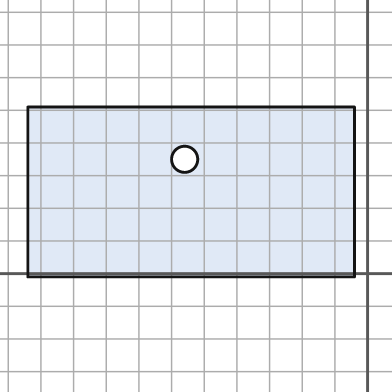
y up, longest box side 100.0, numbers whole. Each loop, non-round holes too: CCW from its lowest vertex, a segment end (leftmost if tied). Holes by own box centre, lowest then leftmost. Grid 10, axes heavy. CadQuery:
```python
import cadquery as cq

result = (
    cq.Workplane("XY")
    .moveTo(-104.0, -1.0)
    .lineTo(-4.0, -1.0)
    .lineTo(-4.0, 51.0)
    .lineTo(-104.0, 51.0)
    .close()
    .moveTo(-56.0, 35.0)
    .circle(4.0)
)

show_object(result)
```